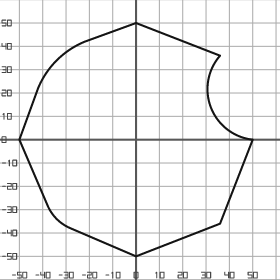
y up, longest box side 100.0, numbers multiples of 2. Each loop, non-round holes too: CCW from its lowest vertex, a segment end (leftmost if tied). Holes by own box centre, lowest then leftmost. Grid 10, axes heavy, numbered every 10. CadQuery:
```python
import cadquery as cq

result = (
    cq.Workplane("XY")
    .moveTo(0.0, -50.0)
    .lineTo(36.0, -36.0)
    .lineTo(50.0, 0.0)
    .threePointArc((32.0, 14.0), (36.0, 36.0))
    .lineTo(0.0, 50.0)
    .lineTo(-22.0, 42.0)
    .threePointArc((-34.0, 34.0), (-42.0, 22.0))
    .lineTo(-50.0, 0.0)
    .lineTo(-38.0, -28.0)
    .threePointArc((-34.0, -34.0), (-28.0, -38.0))
    .close()
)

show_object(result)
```